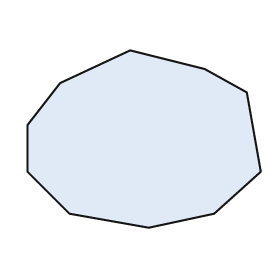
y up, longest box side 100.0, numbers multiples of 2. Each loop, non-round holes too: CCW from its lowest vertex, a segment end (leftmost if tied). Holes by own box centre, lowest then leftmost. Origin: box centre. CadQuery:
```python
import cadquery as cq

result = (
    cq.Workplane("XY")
    .moveTo(2.0, -38.0)
    .lineTo(30.0, -32.0)
    .lineTo(50.0, -14.0)
    .lineTo(44.0, 20.0)
    .lineTo(26.0, 30.0)
    .lineTo(-6.0, 38.0)
    .lineTo(-36.0, 24.0)
    .lineTo(-50.0, 6.0)
    .lineTo(-50.0, -14.0)
    .lineTo(-32.0, -32.0)
    .close()
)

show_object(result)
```